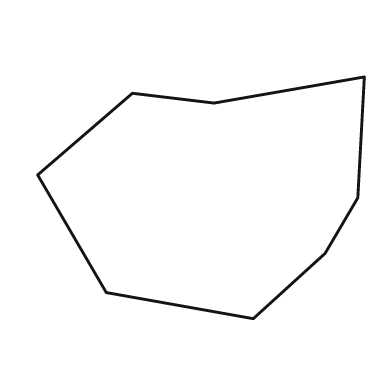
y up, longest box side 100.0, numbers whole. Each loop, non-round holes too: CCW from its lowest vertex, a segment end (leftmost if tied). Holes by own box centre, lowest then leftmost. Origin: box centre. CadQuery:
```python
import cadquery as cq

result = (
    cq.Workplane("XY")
    .moveTo(16.0, -37.0)
    .lineTo(38.0, -17.0)
    .lineTo(48.0, 0.0)
    .lineTo(50.0, 37.0)
    .lineTo(4.0, 29.0)
    .lineTo(-21.0, 32.0)
    .lineTo(-50.0, 7.0)
    .lineTo(-29.0, -29.0)
    .close()
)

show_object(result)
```